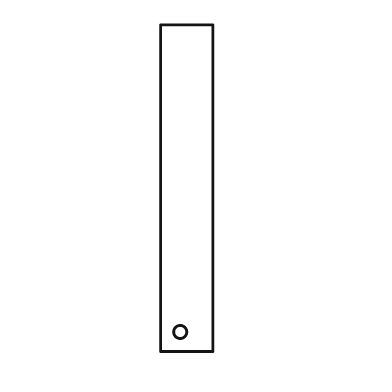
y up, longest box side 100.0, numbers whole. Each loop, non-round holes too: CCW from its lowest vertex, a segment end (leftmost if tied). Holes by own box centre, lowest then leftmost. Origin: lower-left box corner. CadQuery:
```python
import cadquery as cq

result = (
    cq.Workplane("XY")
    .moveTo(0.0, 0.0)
    .lineTo(16.0, 0.0)
    .lineTo(16.0, 100.0)
    .lineTo(0.0, 100.0)
    .close()
    .moveTo(6.0, 6.0)
    .circle(2.0)
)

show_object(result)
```